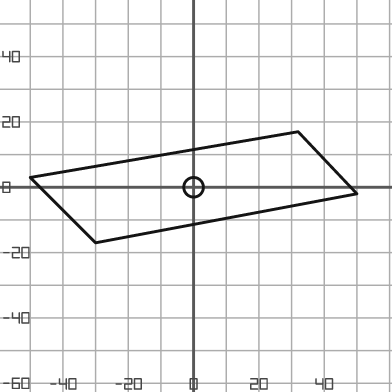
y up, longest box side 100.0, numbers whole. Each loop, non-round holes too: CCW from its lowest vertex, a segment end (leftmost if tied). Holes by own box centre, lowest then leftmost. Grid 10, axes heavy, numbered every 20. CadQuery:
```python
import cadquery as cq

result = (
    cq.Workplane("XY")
    .moveTo(-30.0, -17.0)
    .lineTo(50.0, -2.0)
    .lineTo(32.0, 17.0)
    .lineTo(-50.0, 3.0)
    .close()
    .moveTo(0.0, 0.0)
    .circle(3.0)
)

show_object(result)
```